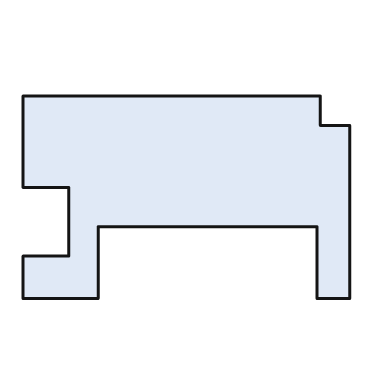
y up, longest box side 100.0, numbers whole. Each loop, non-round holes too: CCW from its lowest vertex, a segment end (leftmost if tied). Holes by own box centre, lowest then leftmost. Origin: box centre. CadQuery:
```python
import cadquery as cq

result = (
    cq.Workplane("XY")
    .moveTo(-50.0, -31.0)
    .lineTo(-27.0, -31.0)
    .lineTo(-27.0, -9.0)
    .lineTo(40.0, -9.0)
    .lineTo(40.0, -31.0)
    .lineTo(50.0, -31.0)
    .lineTo(50.0, 22.0)
    .lineTo(41.0, 22.0)
    .lineTo(41.0, 31.0)
    .lineTo(-50.0, 31.0)
    .lineTo(-50.0, 3.0)
    .lineTo(-36.0, 3.0)
    .lineTo(-36.0, -18.0)
    .lineTo(-50.0, -18.0)
    .close()
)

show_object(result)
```